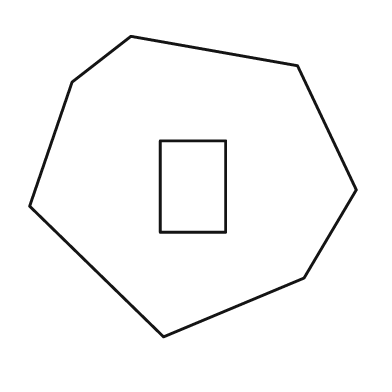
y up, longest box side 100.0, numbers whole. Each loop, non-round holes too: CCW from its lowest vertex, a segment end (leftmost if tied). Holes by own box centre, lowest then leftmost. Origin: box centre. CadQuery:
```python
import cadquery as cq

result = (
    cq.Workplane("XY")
    .moveTo(-9.0, -46.0)
    .lineTo(34.0, -28.0)
    .lineTo(50.0, -1.0)
    .lineTo(32.0, 37.0)
    .lineTo(-19.0, 46.0)
    .lineTo(-37.0, 32.0)
    .lineTo(-50.0, -6.0)
    .close()
    .moveTo(-10.0, -14.0)
    .lineTo(10.0, -14.0)
    .lineTo(10.0, 14.0)
    .lineTo(-10.0, 14.0)
    .close()
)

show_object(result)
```